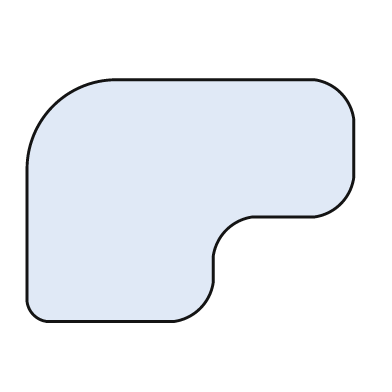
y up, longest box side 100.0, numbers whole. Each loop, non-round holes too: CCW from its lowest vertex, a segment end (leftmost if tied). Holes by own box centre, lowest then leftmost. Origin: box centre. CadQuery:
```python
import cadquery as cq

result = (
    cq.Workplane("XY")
    .moveTo(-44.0, -37.0)
    .lineTo(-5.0, -37.0)
    .threePointArc((3.0, -33.0), (7.0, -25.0))
    .lineTo(7.0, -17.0)
    .threePointArc((11.0, -9.0), (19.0, -5.0))
    .lineTo(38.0, -5.0)
    .threePointArc((46.0, -1.0), (50.0, 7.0))
    .lineTo(50.0, 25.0)
    .threePointArc((46.0, 33.0), (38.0, 37.0))
    .lineTo(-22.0, 37.0)
    .threePointArc((-42.0, 29.0), (-50.0, 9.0))
    .lineTo(-50.0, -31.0)
    .threePointArc((-48.0, -35.0), (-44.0, -37.0))
    .close()
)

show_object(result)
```